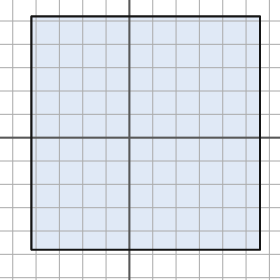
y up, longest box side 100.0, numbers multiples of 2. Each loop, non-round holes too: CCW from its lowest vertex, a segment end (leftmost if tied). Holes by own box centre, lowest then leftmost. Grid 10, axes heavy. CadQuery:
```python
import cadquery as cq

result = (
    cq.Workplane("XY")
    .moveTo(-42.0, -48.0)
    .lineTo(56.0, -48.0)
    .lineTo(56.0, 52.0)
    .lineTo(-42.0, 52.0)
    .close()
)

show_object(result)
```